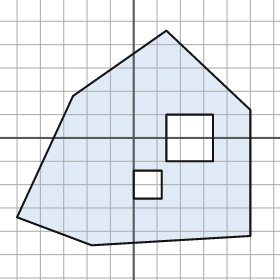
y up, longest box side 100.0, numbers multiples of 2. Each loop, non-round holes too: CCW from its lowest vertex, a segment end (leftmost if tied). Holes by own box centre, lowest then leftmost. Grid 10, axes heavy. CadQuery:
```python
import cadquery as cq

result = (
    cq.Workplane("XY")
    .moveTo(-18.0, -46.0)
    .lineTo(50.0, -42.0)
    .lineTo(50.0, 12.0)
    .lineTo(14.0, 46.0)
    .lineTo(-26.0, 18.0)
    .lineTo(-50.0, -34.0)
    .close()
    .moveTo(0.0, -26.0)
    .lineTo(12.0, -26.0)
    .lineTo(12.0, -14.0)
    .lineTo(0.0, -14.0)
    .close()
    .moveTo(14.0, -10.0)
    .lineTo(34.0, -10.0)
    .lineTo(34.0, 10.0)
    .lineTo(14.0, 10.0)
    .close()
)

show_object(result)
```